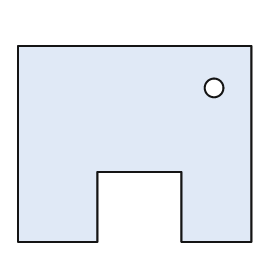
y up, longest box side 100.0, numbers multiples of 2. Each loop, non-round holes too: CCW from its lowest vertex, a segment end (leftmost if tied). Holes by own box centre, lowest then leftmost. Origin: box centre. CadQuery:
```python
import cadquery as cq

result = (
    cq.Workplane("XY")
    .moveTo(-50.0, -42.0)
    .lineTo(-16.0, -42.0)
    .lineTo(-16.0, -12.0)
    .lineTo(20.0, -12.0)
    .lineTo(20.0, -42.0)
    .lineTo(50.0, -42.0)
    .lineTo(50.0, 42.0)
    .lineTo(-50.0, 42.0)
    .close()
    .moveTo(34.0, 24.0)
    .circle(4.0)
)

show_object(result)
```